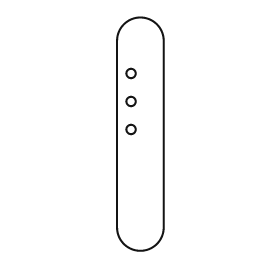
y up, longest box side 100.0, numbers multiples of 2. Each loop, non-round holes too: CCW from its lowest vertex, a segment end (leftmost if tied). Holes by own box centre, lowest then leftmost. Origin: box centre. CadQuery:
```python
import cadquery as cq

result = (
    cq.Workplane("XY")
    .moveTo(-10.0, -40.0)
    .threePointArc((0.0, -50.0), (10.0, -40.0))
    .lineTo(10.0, 40.0)
    .threePointArc((0.0, 50.0), (-10.0, 40.0))
    .close()
    .moveTo(-4.0, 2.0)
    .circle(2.0)
    .moveTo(-4.0, 14.0)
    .circle(2.0)
    .moveTo(-4.0, 26.0)
    .circle(2.0)
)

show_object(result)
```